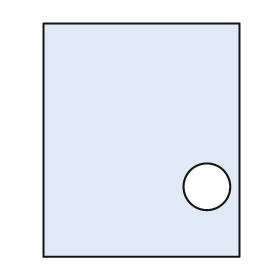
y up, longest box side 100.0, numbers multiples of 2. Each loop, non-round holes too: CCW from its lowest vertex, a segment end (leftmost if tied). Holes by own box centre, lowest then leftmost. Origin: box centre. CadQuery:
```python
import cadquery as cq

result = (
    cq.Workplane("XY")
    .moveTo(-42.0, -50.0)
    .lineTo(42.0, -50.0)
    .lineTo(42.0, 50.0)
    .lineTo(-42.0, 50.0)
    .close()
    .moveTo(28.0, -20.0)
    .circle(10.0)
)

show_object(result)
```